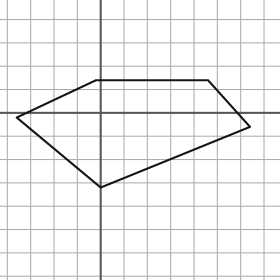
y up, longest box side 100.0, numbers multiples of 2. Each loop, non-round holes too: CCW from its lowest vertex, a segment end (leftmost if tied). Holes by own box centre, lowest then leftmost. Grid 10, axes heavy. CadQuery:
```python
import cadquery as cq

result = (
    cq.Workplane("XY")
    .moveTo(0.0, -32.0)
    .lineTo(64.0, -6.0)
    .lineTo(46.0, 14.0)
    .lineTo(-2.0, 14.0)
    .lineTo(-36.0, -2.0)
    .close()
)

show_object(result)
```